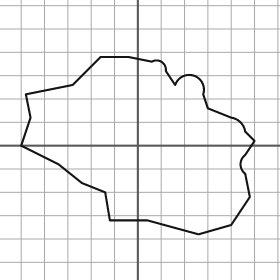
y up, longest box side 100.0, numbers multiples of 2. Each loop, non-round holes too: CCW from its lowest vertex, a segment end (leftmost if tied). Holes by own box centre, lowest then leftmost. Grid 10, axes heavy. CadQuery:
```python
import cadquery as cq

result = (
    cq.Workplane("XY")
    .moveTo(26.0, -38.0)
    .lineTo(40.0, -34.0)
    .lineTo(48.0, -22.0)
    .lineTo(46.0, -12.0)
    .threePointArc((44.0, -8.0), (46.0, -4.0))
    .lineTo(50.0, 2.0)
    .lineTo(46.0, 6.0)
    .threePointArc((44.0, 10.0), (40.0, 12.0))
    .lineTo(30.0, 16.0)
    .lineTo(28.0, 22.0)
    .threePointArc((24.0, 30.0), (16.0, 26.0))
    .lineTo(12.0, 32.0)
    .threePointArc((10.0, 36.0), (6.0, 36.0))
    .lineTo(-4.0, 38.0)
    .lineTo(-16.0, 38.0)
    .lineTo(-28.0, 26.0)
    .lineTo(-48.0, 22.0)
    .lineTo(-46.0, 12.0)
    .lineTo(-50.0, 0.0)
    .lineTo(-34.0, -8.0)
    .lineTo(-24.0, -16.0)
    .lineTo(-14.0, -20.0)
    .lineTo(-12.0, -32.0)
    .lineTo(4.0, -32.0)
    .close()
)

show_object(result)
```